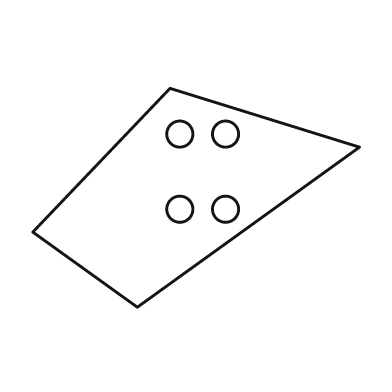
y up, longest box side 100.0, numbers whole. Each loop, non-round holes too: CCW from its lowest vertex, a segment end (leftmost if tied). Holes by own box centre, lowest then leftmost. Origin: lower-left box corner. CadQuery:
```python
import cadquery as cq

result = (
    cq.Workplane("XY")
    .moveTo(32.0, 0.0)
    .lineTo(100.0, 49.0)
    .lineTo(42.0, 67.0)
    .lineTo(0.0, 23.0)
    .close()
    .moveTo(45.0, 30.0)
    .circle(4.0)
    .moveTo(59.0, 30.0)
    .circle(4.0)
    .moveTo(45.0, 53.0)
    .circle(4.0)
    .moveTo(59.0, 53.0)
    .circle(4.0)
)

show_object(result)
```